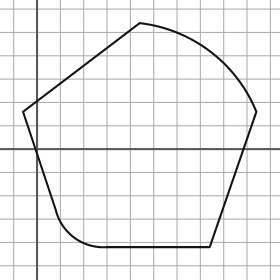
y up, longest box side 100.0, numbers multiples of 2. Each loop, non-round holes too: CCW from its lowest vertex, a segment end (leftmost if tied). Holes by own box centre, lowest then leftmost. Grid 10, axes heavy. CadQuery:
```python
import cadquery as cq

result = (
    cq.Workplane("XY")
    .moveTo(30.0, -42.0)
    .lineTo(74.0, -42.0)
    .lineTo(94.0, 16.0)
    .threePointArc((74.0, 42.0), (44.0, 54.0))
    .lineTo(-6.0, 16.0)
    .lineTo(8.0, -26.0)
    .threePointArc((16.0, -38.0), (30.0, -42.0))
    .close()
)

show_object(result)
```